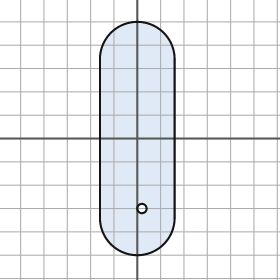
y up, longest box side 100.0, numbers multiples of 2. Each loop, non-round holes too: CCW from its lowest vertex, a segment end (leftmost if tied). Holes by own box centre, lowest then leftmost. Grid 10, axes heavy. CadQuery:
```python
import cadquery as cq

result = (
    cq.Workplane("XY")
    .moveTo(-16.0, -34.0)
    .threePointArc((0.0, -50.0), (16.0, -34.0))
    .lineTo(16.0, 34.0)
    .threePointArc((0.0, 50.0), (-16.0, 34.0))
    .close()
    .moveTo(2.0, -30.0)
    .circle(2.0)
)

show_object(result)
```